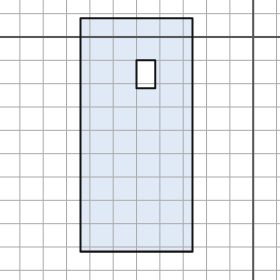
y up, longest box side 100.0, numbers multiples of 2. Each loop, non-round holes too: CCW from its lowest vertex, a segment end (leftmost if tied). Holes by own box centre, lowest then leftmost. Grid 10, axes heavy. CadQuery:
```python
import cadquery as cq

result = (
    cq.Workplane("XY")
    .moveTo(-74.0, -92.0)
    .lineTo(-26.0, -92.0)
    .lineTo(-26.0, 8.0)
    .lineTo(-74.0, 8.0)
    .close()
    .moveTo(-50.0, -22.0)
    .lineTo(-42.0, -22.0)
    .lineTo(-42.0, -10.0)
    .lineTo(-50.0, -10.0)
    .close()
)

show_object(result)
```